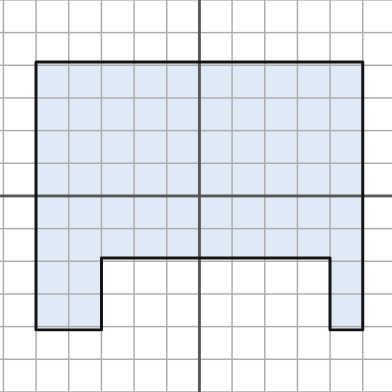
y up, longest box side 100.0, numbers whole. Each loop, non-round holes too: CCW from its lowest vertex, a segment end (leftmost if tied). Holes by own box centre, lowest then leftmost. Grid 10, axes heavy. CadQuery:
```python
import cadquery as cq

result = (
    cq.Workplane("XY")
    .moveTo(-50.0, -41.0)
    .lineTo(-30.0, -41.0)
    .lineTo(-30.0, -19.0)
    .lineTo(40.0, -19.0)
    .lineTo(40.0, -41.0)
    .lineTo(50.0, -41.0)
    .lineTo(50.0, 41.0)
    .lineTo(-50.0, 41.0)
    .close()
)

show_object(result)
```